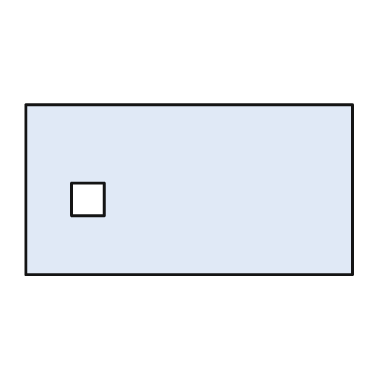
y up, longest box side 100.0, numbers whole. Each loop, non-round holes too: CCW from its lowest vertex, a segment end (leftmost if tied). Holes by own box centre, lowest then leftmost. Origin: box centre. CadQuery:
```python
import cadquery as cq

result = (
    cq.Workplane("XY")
    .moveTo(-50.0, -26.0)
    .lineTo(50.0, -26.0)
    .lineTo(50.0, 26.0)
    .lineTo(-50.0, 26.0)
    .close()
    .moveTo(-36.0, -8.0)
    .lineTo(-26.0, -8.0)
    .lineTo(-26.0, 2.0)
    .lineTo(-36.0, 2.0)
    .close()
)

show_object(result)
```